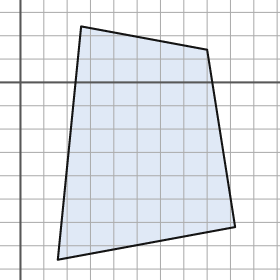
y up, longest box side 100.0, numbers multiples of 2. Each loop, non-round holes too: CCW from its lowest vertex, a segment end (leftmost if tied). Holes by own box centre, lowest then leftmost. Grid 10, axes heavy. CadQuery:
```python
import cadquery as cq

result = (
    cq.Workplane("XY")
    .moveTo(16.0, -76.0)
    .lineTo(92.0, -62.0)
    .lineTo(80.0, 14.0)
    .lineTo(26.0, 24.0)
    .close()
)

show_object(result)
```